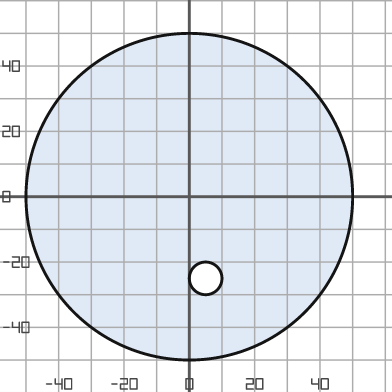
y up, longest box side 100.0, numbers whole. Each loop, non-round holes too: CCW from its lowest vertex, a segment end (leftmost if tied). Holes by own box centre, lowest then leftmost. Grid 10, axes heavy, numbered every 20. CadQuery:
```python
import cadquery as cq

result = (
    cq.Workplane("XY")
    .moveTo(0.0, 0.0)
    .circle(50.0)
    .moveTo(5.0, -25.0)
    .circle(5.0)
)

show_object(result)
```